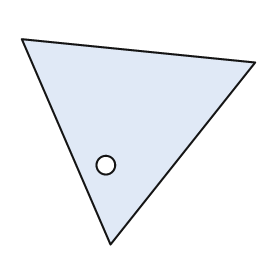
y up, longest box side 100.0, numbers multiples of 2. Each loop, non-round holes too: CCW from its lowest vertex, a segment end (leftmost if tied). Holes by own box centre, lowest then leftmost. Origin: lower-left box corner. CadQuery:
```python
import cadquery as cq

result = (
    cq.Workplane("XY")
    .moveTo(38.0, 0.0)
    .lineTo(100.0, 78.0)
    .lineTo(0.0, 88.0)
    .close()
    .moveTo(36.0, 34.0)
    .circle(4.0)
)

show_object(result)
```